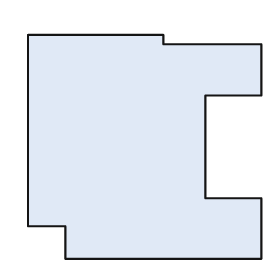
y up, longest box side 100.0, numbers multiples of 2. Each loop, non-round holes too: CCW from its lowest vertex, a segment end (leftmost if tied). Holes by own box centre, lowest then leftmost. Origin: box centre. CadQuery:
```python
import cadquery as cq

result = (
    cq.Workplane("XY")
    .moveTo(-34.0, -48.0)
    .lineTo(50.0, -48.0)
    .lineTo(50.0, -22.0)
    .lineTo(26.0, -22.0)
    .lineTo(26.0, 22.0)
    .lineTo(50.0, 22.0)
    .lineTo(50.0, 44.0)
    .lineTo(8.0, 44.0)
    .lineTo(8.0, 48.0)
    .lineTo(-50.0, 48.0)
    .lineTo(-50.0, -34.0)
    .lineTo(-34.0, -34.0)
    .close()
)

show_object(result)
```